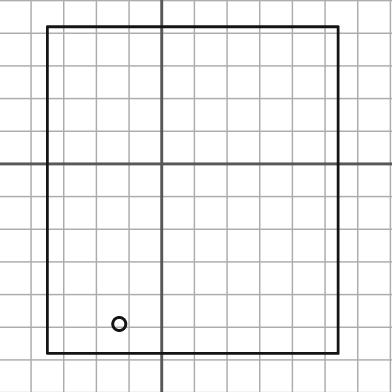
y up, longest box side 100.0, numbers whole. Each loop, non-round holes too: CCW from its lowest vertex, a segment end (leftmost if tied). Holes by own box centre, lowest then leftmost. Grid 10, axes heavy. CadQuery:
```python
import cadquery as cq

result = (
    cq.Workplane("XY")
    .moveTo(-35.0, -58.0)
    .lineTo(54.0, -58.0)
    .lineTo(54.0, 42.0)
    .lineTo(-35.0, 42.0)
    .close()
    .moveTo(-13.0, -49.0)
    .circle(2.0)
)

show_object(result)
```